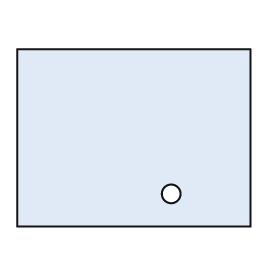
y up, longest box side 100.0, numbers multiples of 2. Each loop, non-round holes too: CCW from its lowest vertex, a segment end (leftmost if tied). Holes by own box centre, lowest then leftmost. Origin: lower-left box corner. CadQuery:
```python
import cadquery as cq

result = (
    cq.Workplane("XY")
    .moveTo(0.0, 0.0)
    .lineTo(100.0, 0.0)
    .lineTo(100.0, 76.0)
    .lineTo(0.0, 76.0)
    .close()
    .moveTo(66.0, 14.0)
    .circle(4.0)
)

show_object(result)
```